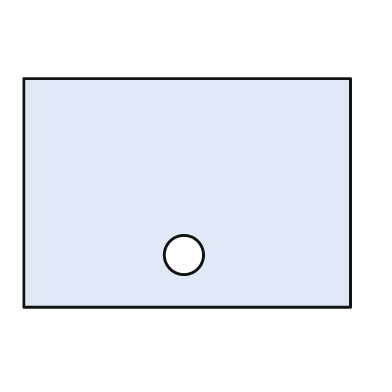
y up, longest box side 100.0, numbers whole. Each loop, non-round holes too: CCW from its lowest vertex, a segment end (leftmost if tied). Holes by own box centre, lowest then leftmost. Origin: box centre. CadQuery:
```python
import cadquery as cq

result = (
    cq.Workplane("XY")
    .moveTo(-50.0, -35.0)
    .lineTo(50.0, -35.0)
    .lineTo(50.0, 35.0)
    .lineTo(-50.0, 35.0)
    .close()
    .moveTo(-1.0, -19.0)
    .circle(6.0)
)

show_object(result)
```